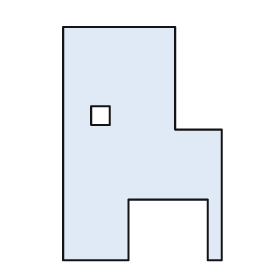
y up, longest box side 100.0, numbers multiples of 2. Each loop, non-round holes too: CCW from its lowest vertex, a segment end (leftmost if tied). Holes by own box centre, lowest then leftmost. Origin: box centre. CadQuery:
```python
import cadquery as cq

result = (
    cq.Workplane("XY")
    .moveTo(-34.0, -50.0)
    .lineTo(-6.0, -50.0)
    .lineTo(-6.0, -24.0)
    .lineTo(28.0, -24.0)
    .lineTo(28.0, -50.0)
    .lineTo(34.0, -50.0)
    .lineTo(34.0, 6.0)
    .lineTo(14.0, 6.0)
    .lineTo(14.0, 50.0)
    .lineTo(-34.0, 50.0)
    .close()
    .moveTo(-22.0, 8.0)
    .lineTo(-14.0, 8.0)
    .lineTo(-14.0, 16.0)
    .lineTo(-22.0, 16.0)
    .close()
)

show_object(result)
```